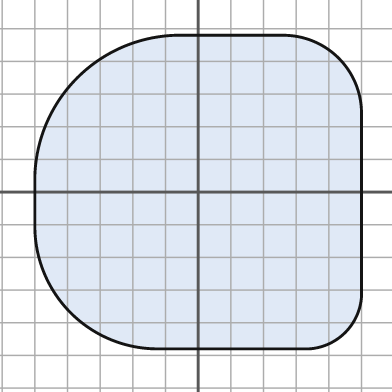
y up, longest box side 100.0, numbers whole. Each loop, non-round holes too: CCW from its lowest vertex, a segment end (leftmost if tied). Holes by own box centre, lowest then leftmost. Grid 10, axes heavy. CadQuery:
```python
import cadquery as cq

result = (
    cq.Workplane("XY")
    .moveTo(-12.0, -48.0)
    .lineTo(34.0, -48.0)
    .threePointArc((45.0, -43.0), (50.0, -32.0))
    .lineTo(50.0, 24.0)
    .threePointArc((43.0, 41.0), (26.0, 48.0))
    .lineTo(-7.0, 48.0)
    .threePointArc((-37.0, 35.0), (-50.0, 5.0))
    .lineTo(-50.0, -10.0)
    .threePointArc((-39.0, -37.0), (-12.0, -48.0))
    .close()
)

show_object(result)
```